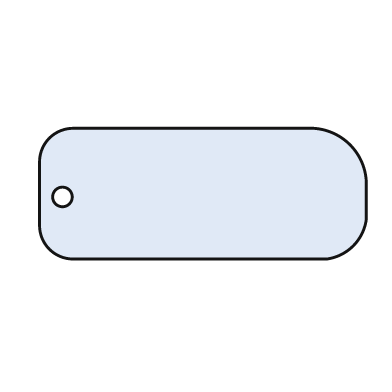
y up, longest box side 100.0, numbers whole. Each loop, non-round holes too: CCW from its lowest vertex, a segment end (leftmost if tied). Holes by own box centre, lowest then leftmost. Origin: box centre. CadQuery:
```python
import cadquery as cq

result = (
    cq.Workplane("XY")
    .moveTo(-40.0, -20.0)
    .lineTo(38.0, -20.0)
    .threePointArc((46.0, -16.0), (50.0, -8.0))
    .lineTo(50.0, 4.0)
    .threePointArc((45.0, 15.0), (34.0, 20.0))
    .lineTo(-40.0, 20.0)
    .threePointArc((-47.0, 17.0), (-50.0, 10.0))
    .lineTo(-50.0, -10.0)
    .threePointArc((-47.0, -17.0), (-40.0, -20.0))
    .close()
    .moveTo(-43.0, -1.0)
    .circle(3.0)
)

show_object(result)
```